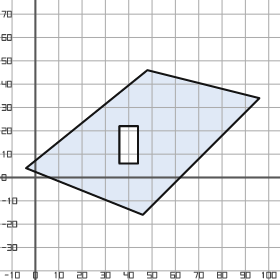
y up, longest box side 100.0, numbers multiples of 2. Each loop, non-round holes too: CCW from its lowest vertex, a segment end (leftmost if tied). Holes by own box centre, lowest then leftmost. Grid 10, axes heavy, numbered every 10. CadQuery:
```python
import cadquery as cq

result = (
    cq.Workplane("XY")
    .moveTo(46.0, -16.0)
    .lineTo(96.0, 34.0)
    .lineTo(48.0, 46.0)
    .lineTo(-4.0, 4.0)
    .close()
    .moveTo(36.0, 6.0)
    .lineTo(44.0, 6.0)
    .lineTo(44.0, 22.0)
    .lineTo(36.0, 22.0)
    .close()
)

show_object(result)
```